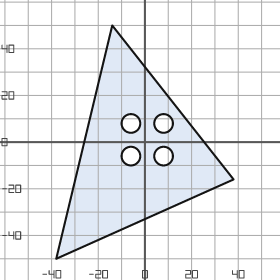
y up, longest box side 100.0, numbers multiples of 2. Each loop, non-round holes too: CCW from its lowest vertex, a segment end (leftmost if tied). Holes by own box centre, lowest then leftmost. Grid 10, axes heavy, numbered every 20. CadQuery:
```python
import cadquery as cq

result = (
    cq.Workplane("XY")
    .moveTo(-38.0, -50.0)
    .lineTo(38.0, -16.0)
    .lineTo(-14.0, 50.0)
    .close()
    .moveTo(-6.0, -6.0)
    .circle(4.0)
    .moveTo(8.0, -6.0)
    .circle(4.0)
    .moveTo(-6.0, 8.0)
    .circle(4.0)
    .moveTo(8.0, 8.0)
    .circle(4.0)
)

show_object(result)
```